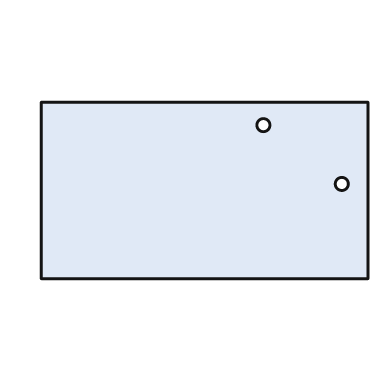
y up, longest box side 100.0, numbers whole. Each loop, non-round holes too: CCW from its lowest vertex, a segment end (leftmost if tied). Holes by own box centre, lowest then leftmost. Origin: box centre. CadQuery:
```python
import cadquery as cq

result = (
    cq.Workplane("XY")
    .moveTo(-50.0, -27.0)
    .lineTo(50.0, -27.0)
    .lineTo(50.0, 27.0)
    .lineTo(-50.0, 27.0)
    .close()
    .moveTo(42.0, 2.0)
    .circle(2.0)
    .moveTo(18.0, 20.0)
    .circle(2.0)
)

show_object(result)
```